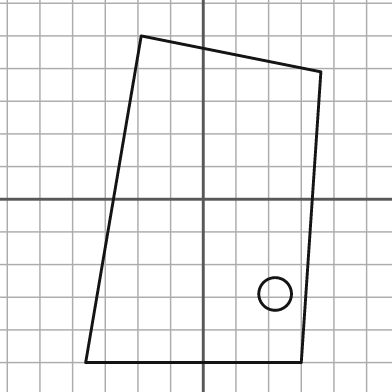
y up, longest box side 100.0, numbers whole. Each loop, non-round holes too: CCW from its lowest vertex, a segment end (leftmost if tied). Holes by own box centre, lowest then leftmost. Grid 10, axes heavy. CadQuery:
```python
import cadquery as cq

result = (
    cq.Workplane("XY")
    .moveTo(-36.0, -50.0)
    .lineTo(30.0, -50.0)
    .lineTo(36.0, 39.0)
    .lineTo(-19.0, 50.0)
    .close()
    .moveTo(22.0, -29.0)
    .circle(5.0)
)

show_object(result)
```